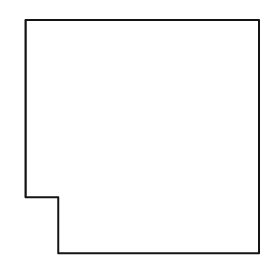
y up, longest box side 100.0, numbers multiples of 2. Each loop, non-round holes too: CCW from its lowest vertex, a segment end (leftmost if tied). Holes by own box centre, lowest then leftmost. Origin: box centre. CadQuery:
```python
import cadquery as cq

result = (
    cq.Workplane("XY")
    .moveTo(-36.0, -50.0)
    .lineTo(50.0, -50.0)
    .lineTo(50.0, 50.0)
    .lineTo(-50.0, 50.0)
    .lineTo(-50.0, -26.0)
    .lineTo(-36.0, -26.0)
    .close()
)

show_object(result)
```